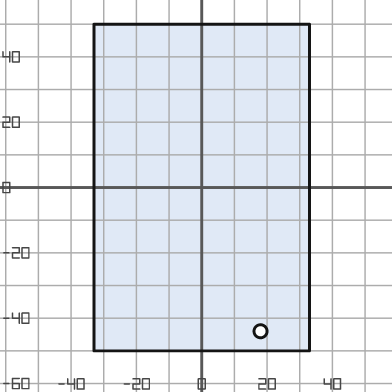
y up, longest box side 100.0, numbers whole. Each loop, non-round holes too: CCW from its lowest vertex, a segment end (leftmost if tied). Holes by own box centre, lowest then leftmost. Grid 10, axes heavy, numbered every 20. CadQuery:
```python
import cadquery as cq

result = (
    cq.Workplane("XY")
    .moveTo(-33.0, -50.0)
    .lineTo(33.0, -50.0)
    .lineTo(33.0, 50.0)
    .lineTo(-33.0, 50.0)
    .close()
    .moveTo(18.0, -44.0)
    .circle(2.0)
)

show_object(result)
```